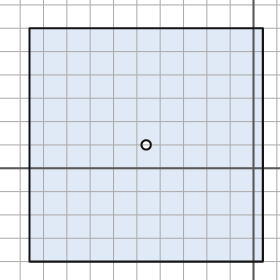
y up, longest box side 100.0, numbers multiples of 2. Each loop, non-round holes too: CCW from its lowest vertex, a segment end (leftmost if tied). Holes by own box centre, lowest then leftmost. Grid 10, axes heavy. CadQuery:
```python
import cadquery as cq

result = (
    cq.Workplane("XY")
    .moveTo(-96.0, -40.0)
    .lineTo(4.0, -40.0)
    .lineTo(4.0, 60.0)
    .lineTo(-96.0, 60.0)
    .close()
    .moveTo(-46.0, 10.0)
    .circle(2.0)
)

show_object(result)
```